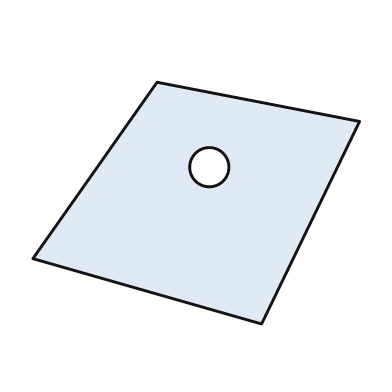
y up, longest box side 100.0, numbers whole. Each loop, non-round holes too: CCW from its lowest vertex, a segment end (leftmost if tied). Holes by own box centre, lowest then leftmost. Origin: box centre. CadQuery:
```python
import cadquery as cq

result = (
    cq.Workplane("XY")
    .moveTo(20.0, -37.0)
    .lineTo(50.0, 25.0)
    .lineTo(-12.0, 37.0)
    .lineTo(-50.0, -17.0)
    .close()
    .moveTo(4.0, 11.0)
    .circle(6.0)
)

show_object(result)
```